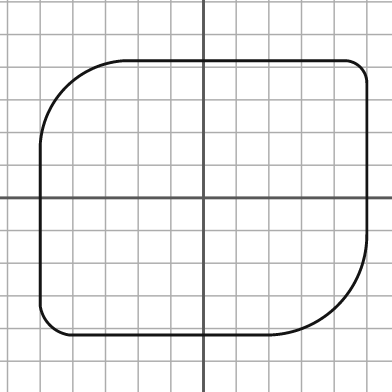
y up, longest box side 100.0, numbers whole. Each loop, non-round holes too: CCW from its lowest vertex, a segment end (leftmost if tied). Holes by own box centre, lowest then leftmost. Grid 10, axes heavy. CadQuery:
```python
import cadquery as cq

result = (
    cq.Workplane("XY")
    .moveTo(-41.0, -42.0)
    .lineTo(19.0, -42.0)
    .threePointArc((41.0, -33.0), (50.0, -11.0))
    .lineTo(50.0, 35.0)
    .threePointArc((48.0, 40.0), (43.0, 42.0))
    .lineTo(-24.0, 42.0)
    .threePointArc((-42.0, 34.0), (-50.0, 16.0))
    .lineTo(-50.0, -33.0)
    .threePointArc((-47.0, -39.0), (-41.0, -42.0))
    .close()
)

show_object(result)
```